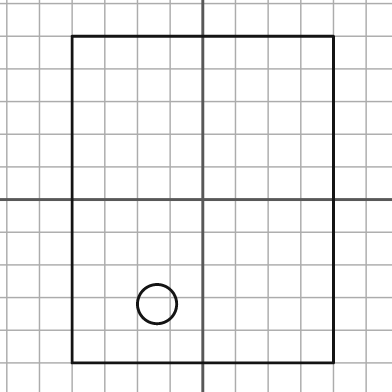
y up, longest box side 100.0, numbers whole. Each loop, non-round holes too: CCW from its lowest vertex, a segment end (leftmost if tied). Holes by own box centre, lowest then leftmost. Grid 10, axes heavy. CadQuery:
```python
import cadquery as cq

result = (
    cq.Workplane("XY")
    .moveTo(-40.0, -50.0)
    .lineTo(40.0, -50.0)
    .lineTo(40.0, 50.0)
    .lineTo(-40.0, 50.0)
    .close()
    .moveTo(-14.0, -32.0)
    .circle(6.0)
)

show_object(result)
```